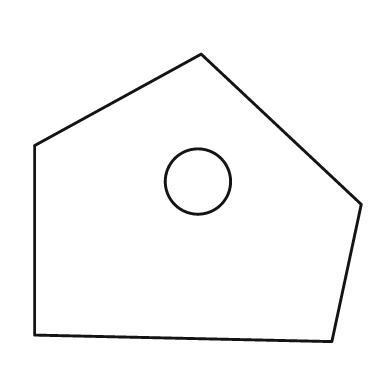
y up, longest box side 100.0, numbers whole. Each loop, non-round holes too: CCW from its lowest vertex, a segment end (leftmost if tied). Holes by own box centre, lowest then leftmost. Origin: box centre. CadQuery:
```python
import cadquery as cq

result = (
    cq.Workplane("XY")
    .moveTo(41.0, -44.0)
    .lineTo(50.0, -2.0)
    .lineTo(1.0, 44.0)
    .lineTo(-50.0, 16.0)
    .lineTo(-50.0, -42.0)
    .close()
    .moveTo(0.0, 5.0)
    .circle(10.0)
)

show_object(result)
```